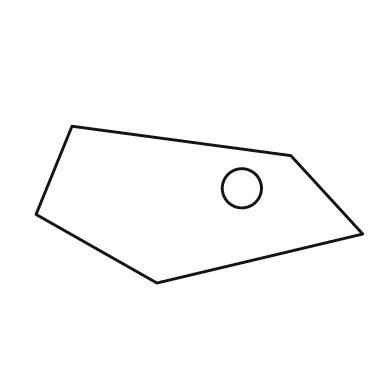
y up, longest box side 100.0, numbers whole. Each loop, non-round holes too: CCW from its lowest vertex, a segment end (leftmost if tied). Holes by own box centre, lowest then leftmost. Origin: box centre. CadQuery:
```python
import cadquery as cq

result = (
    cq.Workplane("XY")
    .moveTo(-13.0, -24.0)
    .lineTo(50.0, -9.0)
    .lineTo(28.0, 15.0)
    .lineTo(-39.0, 24.0)
    .lineTo(-50.0, -3.0)
    .close()
    .moveTo(13.0, 5.0)
    .circle(6.0)
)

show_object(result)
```